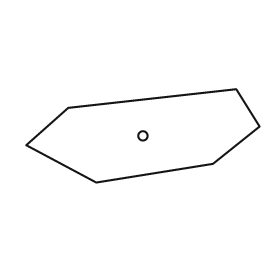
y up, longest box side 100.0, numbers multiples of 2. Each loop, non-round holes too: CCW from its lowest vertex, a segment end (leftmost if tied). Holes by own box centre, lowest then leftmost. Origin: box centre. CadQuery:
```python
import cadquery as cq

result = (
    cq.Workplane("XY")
    .moveTo(-20.0, -20.0)
    .lineTo(30.0, -12.0)
    .lineTo(50.0, 4.0)
    .lineTo(40.0, 20.0)
    .lineTo(-32.0, 12.0)
    .lineTo(-50.0, -4.0)
    .close()
    .moveTo(0.0, 0.0)
    .circle(2.0)
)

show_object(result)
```